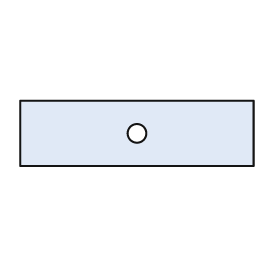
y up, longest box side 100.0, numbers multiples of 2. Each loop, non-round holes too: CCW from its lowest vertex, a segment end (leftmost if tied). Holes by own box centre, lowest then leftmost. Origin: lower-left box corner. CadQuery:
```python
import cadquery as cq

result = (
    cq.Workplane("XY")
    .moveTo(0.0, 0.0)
    .lineTo(100.0, 0.0)
    .lineTo(100.0, 28.0)
    .lineTo(0.0, 28.0)
    .close()
    .moveTo(50.0, 14.0)
    .circle(4.0)
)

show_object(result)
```